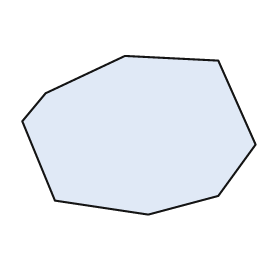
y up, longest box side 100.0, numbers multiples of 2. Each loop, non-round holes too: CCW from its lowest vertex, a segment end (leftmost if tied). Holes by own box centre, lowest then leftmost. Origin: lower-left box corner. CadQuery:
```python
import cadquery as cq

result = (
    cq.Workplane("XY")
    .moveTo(54.0, 0.0)
    .lineTo(84.0, 8.0)
    .lineTo(100.0, 30.0)
    .lineTo(84.0, 66.0)
    .lineTo(44.0, 68.0)
    .lineTo(10.0, 52.0)
    .lineTo(0.0, 40.0)
    .lineTo(14.0, 6.0)
    .close()
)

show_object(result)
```